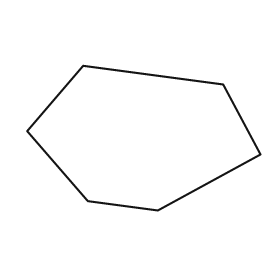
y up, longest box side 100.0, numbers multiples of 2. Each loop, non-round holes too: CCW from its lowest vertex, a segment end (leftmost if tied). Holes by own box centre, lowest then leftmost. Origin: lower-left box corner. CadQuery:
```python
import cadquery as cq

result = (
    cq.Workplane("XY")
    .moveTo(56.0, 0.0)
    .lineTo(100.0, 24.0)
    .lineTo(84.0, 54.0)
    .lineTo(24.0, 62.0)
    .lineTo(0.0, 34.0)
    .lineTo(26.0, 4.0)
    .close()
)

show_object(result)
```